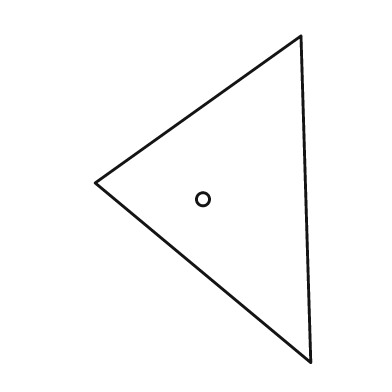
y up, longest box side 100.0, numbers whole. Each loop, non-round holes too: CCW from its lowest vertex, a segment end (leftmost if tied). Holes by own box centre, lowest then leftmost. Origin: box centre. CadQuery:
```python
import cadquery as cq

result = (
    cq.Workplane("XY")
    .moveTo(33.0, -50.0)
    .lineTo(30.0, 50.0)
    .lineTo(-33.0, 5.0)
    .close()
    .moveTo(0.0, 0.0)
    .circle(2.0)
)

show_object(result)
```